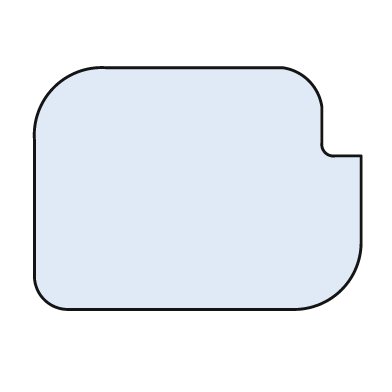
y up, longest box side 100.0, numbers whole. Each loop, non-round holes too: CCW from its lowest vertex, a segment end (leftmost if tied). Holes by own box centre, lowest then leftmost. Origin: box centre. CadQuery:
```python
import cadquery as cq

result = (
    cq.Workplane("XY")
    .moveTo(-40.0, -37.0)
    .lineTo(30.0, -37.0)
    .threePointArc((44.0, -31.0), (50.0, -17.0))
    .lineTo(50.0, 10.0)
    .lineTo(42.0, 10.0)
    .threePointArc((39.0, 11.0), (38.0, 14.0))
    .lineTo(38.0, 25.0)
    .threePointArc((34.0, 33.0), (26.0, 37.0))
    .lineTo(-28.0, 37.0)
    .threePointArc((-44.0, 31.0), (-50.0, 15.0))
    .lineTo(-50.0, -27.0)
    .threePointArc((-47.0, -34.0), (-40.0, -37.0))
    .close()
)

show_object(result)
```